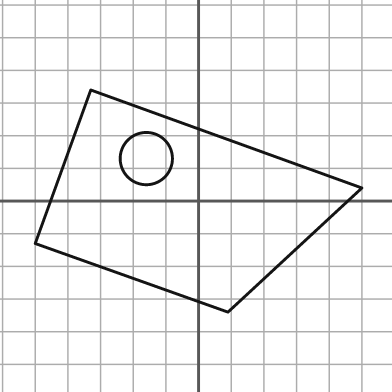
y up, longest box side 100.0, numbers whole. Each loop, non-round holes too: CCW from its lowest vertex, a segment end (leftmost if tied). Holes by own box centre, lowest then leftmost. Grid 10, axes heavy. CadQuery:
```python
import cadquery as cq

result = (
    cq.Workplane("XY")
    .moveTo(9.0, -34.0)
    .lineTo(50.0, 4.0)
    .lineTo(-33.0, 34.0)
    .lineTo(-50.0, -13.0)
    .close()
    .moveTo(-16.0, 13.0)
    .circle(8.0)
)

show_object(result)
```